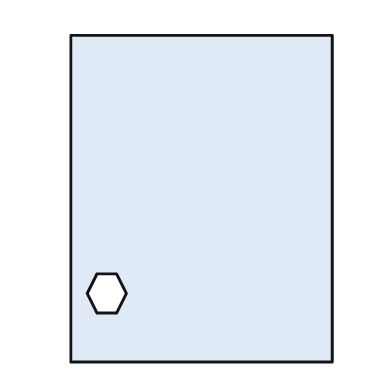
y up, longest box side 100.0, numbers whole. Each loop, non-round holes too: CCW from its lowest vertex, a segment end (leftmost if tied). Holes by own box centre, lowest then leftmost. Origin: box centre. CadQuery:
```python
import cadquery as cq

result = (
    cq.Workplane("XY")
    .moveTo(-40.0, -50.0)
    .lineTo(40.0, -50.0)
    .lineTo(40.0, 50.0)
    .lineTo(-40.0, 50.0)
    .close()
    .moveTo(-32.0, -35.0)
    .lineTo(-26.0, -35.0)
    .lineTo(-23.0, -29.0)
    .lineTo(-26.0, -23.0)
    .lineTo(-32.0, -23.0)
    .lineTo(-35.0, -29.0)
    .close()
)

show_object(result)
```